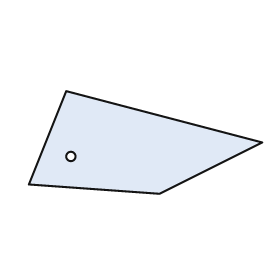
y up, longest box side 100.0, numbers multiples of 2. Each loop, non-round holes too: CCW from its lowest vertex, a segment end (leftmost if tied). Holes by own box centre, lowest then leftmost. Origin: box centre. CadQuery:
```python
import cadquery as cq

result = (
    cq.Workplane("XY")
    .moveTo(6.0, -22.0)
    .lineTo(50.0, 0.0)
    .lineTo(-34.0, 22.0)
    .lineTo(-50.0, -18.0)
    .close()
    .moveTo(-32.0, -6.0)
    .circle(2.0)
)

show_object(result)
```